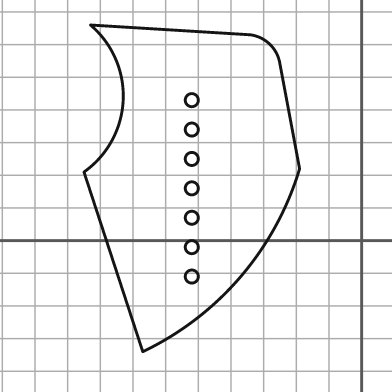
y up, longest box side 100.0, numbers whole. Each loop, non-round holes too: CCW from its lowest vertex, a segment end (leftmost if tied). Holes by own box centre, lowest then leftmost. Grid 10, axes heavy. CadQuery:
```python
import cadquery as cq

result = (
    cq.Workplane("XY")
    .moveTo(-67.0, -34.0)
    .threePointArc((-37.0, -11.0), (-19.0, 22.0))
    .lineTo(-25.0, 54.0)
    .threePointArc((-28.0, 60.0), (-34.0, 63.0))
    .lineTo(-83.0, 66.0)
    .threePointArc((-73.0, 43.0), (-85.0, 21.0))
    .close()
    .moveTo(-52.0, -11.0)
    .circle(2.0)
    .moveTo(-52.0, -2.0)
    .circle(2.0)
    .moveTo(-52.0, 7.0)
    .circle(2.0)
    .moveTo(-52.0, 16.0)
    .circle(2.0)
    .moveTo(-52.0, 25.0)
    .circle(2.0)
    .moveTo(-52.0, 34.0)
    .circle(2.0)
    .moveTo(-52.0, 43.0)
    .circle(2.0)
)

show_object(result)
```